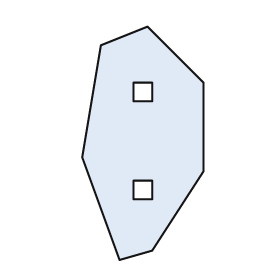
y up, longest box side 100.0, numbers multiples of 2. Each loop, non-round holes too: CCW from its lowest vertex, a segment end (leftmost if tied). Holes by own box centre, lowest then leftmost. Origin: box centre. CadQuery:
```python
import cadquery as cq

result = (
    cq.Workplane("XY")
    .moveTo(-10.0, -50.0)
    .lineTo(4.0, -46.0)
    .lineTo(26.0, -12.0)
    .lineTo(26.0, 26.0)
    .lineTo(2.0, 50.0)
    .lineTo(-18.0, 42.0)
    .lineTo(-26.0, -6.0)
    .close()
    .moveTo(-4.0, -24.0)
    .lineTo(4.0, -24.0)
    .lineTo(4.0, -16.0)
    .lineTo(-4.0, -16.0)
    .close()
    .moveTo(-4.0, 18.0)
    .lineTo(4.0, 18.0)
    .lineTo(4.0, 26.0)
    .lineTo(-4.0, 26.0)
    .close()
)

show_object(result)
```